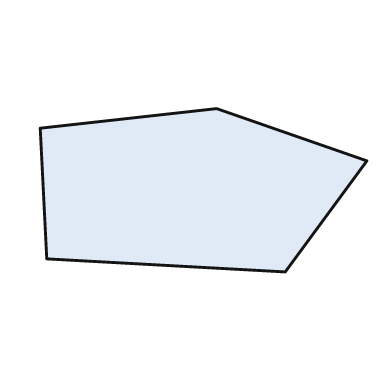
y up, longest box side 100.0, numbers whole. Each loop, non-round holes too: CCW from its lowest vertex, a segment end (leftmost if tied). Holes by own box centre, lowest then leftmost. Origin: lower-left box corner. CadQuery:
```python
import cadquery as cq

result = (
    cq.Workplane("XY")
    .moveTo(75.0, 0.0)
    .lineTo(100.0, 34.0)
    .lineTo(54.0, 50.0)
    .lineTo(0.0, 44.0)
    .lineTo(2.0, 4.0)
    .close()
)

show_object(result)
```